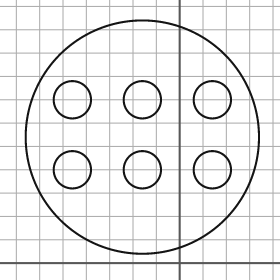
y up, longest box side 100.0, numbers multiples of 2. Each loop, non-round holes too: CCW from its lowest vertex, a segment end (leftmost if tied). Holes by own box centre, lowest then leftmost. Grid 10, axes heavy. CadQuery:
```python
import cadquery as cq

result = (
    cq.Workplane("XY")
    .moveTo(-16.0, 54.0)
    .circle(50.0)
    .moveTo(-46.0, 40.0)
    .circle(8.0)
    .moveTo(-16.0, 40.0)
    .circle(8.0)
    .moveTo(14.0, 40.0)
    .circle(8.0)
    .moveTo(-46.0, 70.0)
    .circle(8.0)
    .moveTo(-16.0, 70.0)
    .circle(8.0)
    .moveTo(14.0, 70.0)
    .circle(8.0)
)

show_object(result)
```